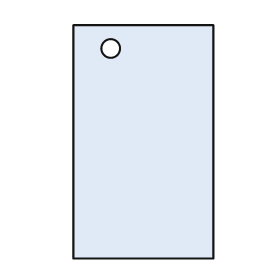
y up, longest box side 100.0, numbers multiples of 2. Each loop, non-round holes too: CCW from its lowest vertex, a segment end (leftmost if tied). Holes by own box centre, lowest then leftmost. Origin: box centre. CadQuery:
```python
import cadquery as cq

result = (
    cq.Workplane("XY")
    .moveTo(-30.0, -50.0)
    .lineTo(30.0, -50.0)
    .lineTo(30.0, 50.0)
    .lineTo(-30.0, 50.0)
    .close()
    .moveTo(-14.0, 40.0)
    .circle(4.0)
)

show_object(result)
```